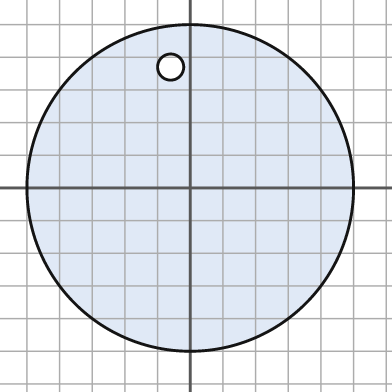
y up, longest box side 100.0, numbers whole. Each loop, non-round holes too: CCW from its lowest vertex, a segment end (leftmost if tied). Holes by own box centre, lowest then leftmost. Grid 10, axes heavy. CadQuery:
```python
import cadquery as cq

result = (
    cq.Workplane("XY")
    .moveTo(0.0, 0.0)
    .circle(50.0)
    .moveTo(-6.0, 37.0)
    .circle(4.0)
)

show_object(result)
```